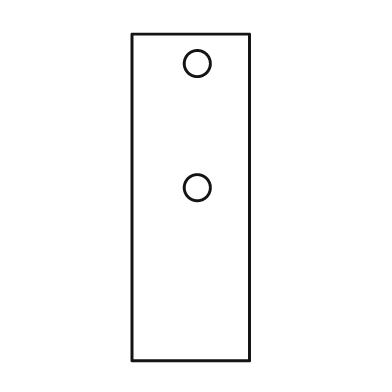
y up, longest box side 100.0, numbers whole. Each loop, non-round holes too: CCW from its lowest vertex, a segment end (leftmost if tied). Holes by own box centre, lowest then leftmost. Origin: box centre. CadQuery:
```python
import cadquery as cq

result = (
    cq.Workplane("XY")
    .moveTo(-18.0, -50.0)
    .lineTo(18.0, -50.0)
    .lineTo(18.0, 50.0)
    .lineTo(-18.0, 50.0)
    .close()
    .moveTo(2.0, 3.0)
    .circle(4.0)
    .moveTo(2.0, 41.0)
    .circle(4.0)
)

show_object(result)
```